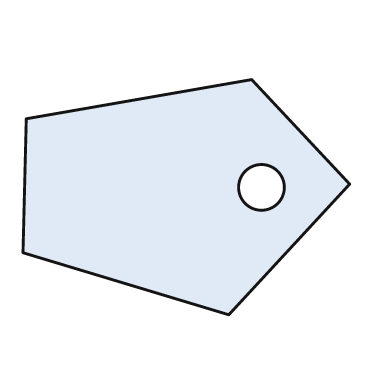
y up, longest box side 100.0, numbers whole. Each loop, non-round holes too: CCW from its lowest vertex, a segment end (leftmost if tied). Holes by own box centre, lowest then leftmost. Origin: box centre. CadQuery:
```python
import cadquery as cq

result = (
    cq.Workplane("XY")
    .moveTo(13.0, -36.0)
    .lineTo(50.0, 4.0)
    .lineTo(20.0, 36.0)
    .lineTo(-49.0, 24.0)
    .lineTo(-50.0, -17.0)
    .close()
    .moveTo(23.0, 3.0)
    .circle(7.0)
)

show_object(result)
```